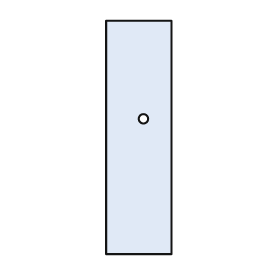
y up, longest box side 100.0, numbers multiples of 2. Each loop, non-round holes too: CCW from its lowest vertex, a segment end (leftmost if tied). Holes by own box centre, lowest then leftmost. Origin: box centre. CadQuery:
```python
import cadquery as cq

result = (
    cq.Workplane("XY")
    .moveTo(-14.0, -50.0)
    .lineTo(14.0, -50.0)
    .lineTo(14.0, 50.0)
    .lineTo(-14.0, 50.0)
    .close()
    .moveTo(2.0, 8.0)
    .circle(2.0)
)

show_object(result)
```